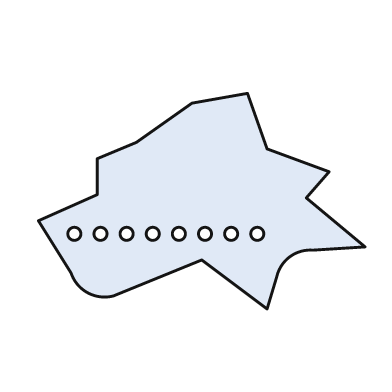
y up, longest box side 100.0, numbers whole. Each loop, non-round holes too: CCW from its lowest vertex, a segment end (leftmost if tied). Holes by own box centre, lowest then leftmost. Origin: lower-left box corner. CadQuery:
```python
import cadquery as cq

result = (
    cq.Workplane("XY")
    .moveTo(70.0, 0.0)
    .lineTo(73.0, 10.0)
    .threePointArc((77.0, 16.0), (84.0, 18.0))
    .lineTo(100.0, 19.0)
    .lineTo(82.0, 34.0)
    .lineTo(89.0, 42.0)
    .lineTo(70.0, 49.0)
    .lineTo(64.0, 66.0)
    .lineTo(47.0, 63.0)
    .lineTo(30.0, 51.0)
    .lineTo(18.0, 46.0)
    .lineTo(18.0, 35.0)
    .lineTo(0.0, 27.0)
    .lineTo(10.0, 11.0)
    .threePointArc((15.0, 5.0), (23.0, 4.0))
    .lineTo(50.0, 15.0)
    .close()
    .moveTo(11.0, 23.0)
    .circle(2.0)
    .moveTo(19.0, 23.0)
    .circle(2.0)
    .moveTo(27.0, 23.0)
    .circle(2.0)
    .moveTo(35.0, 23.0)
    .circle(2.0)
    .moveTo(43.0, 23.0)
    .circle(2.0)
    .moveTo(51.0, 23.0)
    .circle(2.0)
    .moveTo(59.0, 23.0)
    .circle(2.0)
    .moveTo(67.0, 23.0)
    .circle(2.0)
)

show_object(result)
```